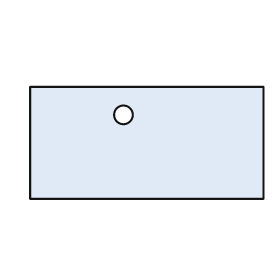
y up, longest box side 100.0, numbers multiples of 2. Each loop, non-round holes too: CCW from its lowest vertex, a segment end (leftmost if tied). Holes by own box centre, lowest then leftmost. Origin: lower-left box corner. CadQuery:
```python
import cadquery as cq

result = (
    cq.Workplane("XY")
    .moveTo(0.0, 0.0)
    .lineTo(100.0, 0.0)
    .lineTo(100.0, 48.0)
    .lineTo(0.0, 48.0)
    .close()
    .moveTo(40.0, 36.0)
    .circle(4.0)
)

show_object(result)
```